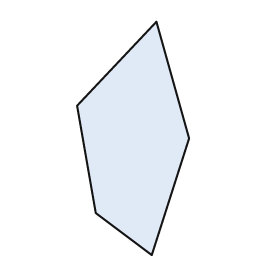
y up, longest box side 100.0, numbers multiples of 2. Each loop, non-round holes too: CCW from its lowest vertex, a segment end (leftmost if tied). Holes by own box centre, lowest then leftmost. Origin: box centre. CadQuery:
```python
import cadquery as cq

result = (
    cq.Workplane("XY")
    .moveTo(8.0, -50.0)
    .lineTo(24.0, 0.0)
    .lineTo(10.0, 50.0)
    .lineTo(-24.0, 14.0)
    .lineTo(-16.0, -32.0)
    .close()
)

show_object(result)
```